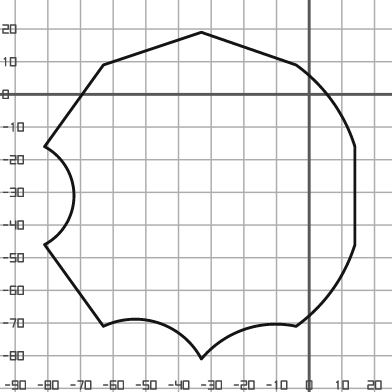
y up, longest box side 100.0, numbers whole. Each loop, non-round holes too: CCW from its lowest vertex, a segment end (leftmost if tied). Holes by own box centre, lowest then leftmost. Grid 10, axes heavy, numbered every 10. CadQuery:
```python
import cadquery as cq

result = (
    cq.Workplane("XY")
    .moveTo(-33.0, -81.0)
    .threePointArc((-20.0, -72.0), (-4.0, -71.0))
    .threePointArc((7.0, -60.0), (14.0, -46.0))
    .lineTo(14.0, -16.0)
    .threePointArc((7.0, -2.0), (-4.0, 9.0))
    .lineTo(-33.0, 19.0)
    .lineTo(-63.0, 9.0)
    .lineTo(-81.0, -16.0)
    .threePointArc((-72.0, -31.0), (-81.0, -46.0))
    .lineTo(-63.0, -71.0)
    .threePointArc((-46.0, -70.0), (-33.0, -81.0))
    .close()
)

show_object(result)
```